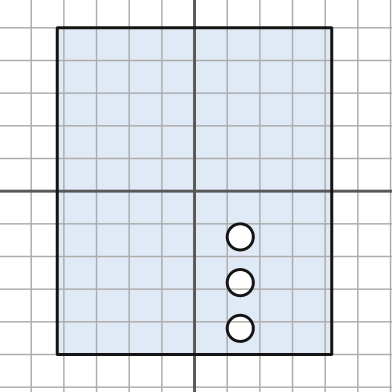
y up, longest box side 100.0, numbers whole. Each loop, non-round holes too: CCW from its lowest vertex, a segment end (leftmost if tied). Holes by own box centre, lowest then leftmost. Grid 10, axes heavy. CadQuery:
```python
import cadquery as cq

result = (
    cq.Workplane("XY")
    .moveTo(-42.0, -50.0)
    .lineTo(42.0, -50.0)
    .lineTo(42.0, 50.0)
    .lineTo(-42.0, 50.0)
    .close()
    .moveTo(14.0, -42.0)
    .circle(4.0)
    .moveTo(14.0, -28.0)
    .circle(4.0)
    .moveTo(14.0, -14.0)
    .circle(4.0)
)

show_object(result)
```